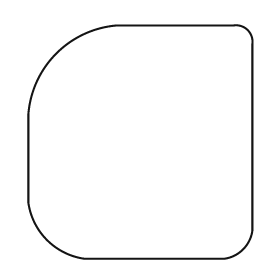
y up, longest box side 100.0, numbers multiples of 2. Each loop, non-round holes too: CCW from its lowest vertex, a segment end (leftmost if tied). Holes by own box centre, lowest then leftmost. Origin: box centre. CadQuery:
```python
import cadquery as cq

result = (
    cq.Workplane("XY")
    .moveTo(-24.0, -50.0)
    .lineTo(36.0, -50.0)
    .threePointArc((44.0, -46.0), (48.0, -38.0))
    .lineTo(48.0, 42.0)
    .threePointArc((46.0, 48.0), (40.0, 50.0))
    .lineTo(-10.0, 50.0)
    .threePointArc((-36.0, 38.0), (-48.0, 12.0))
    .lineTo(-48.0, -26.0)
    .threePointArc((-40.0, -42.0), (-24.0, -50.0))
    .close()
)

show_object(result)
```